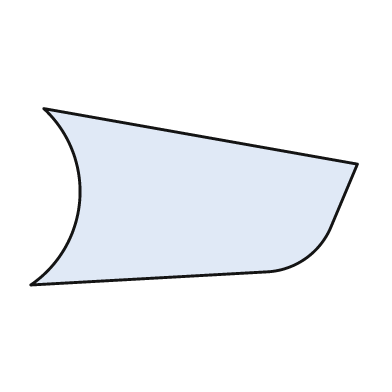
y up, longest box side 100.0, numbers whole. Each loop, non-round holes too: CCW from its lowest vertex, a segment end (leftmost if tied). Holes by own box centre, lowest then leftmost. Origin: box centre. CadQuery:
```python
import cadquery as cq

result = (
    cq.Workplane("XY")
    .moveTo(-50.0, -27.0)
    .lineTo(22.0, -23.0)
    .threePointArc((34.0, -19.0), (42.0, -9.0))
    .lineTo(50.0, 10.0)
    .lineTo(-46.0, 27.0)
    .threePointArc((-35.0, -1.0), (-50.0, -27.0))
    .close()
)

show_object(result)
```